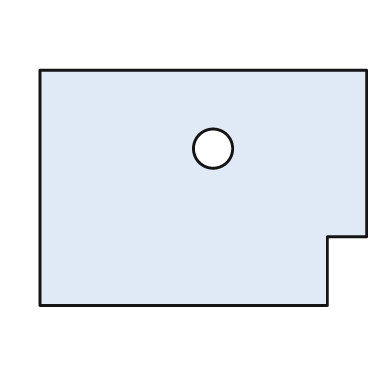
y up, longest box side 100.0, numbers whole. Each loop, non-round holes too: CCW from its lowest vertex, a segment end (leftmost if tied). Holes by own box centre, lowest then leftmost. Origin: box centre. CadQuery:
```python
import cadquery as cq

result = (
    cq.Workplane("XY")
    .moveTo(-50.0, -36.0)
    .lineTo(38.0, -36.0)
    .lineTo(38.0, -15.0)
    .lineTo(50.0, -15.0)
    .lineTo(50.0, 36.0)
    .lineTo(-50.0, 36.0)
    .close()
    .moveTo(3.0, 12.0)
    .circle(6.0)
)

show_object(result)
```